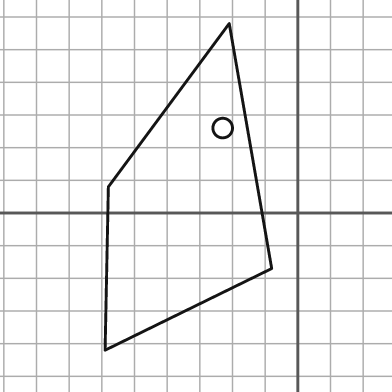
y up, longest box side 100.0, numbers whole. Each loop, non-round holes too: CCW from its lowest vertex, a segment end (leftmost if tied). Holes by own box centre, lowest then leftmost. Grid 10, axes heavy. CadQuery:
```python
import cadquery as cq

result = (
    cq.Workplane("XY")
    .moveTo(-59.0, -42.0)
    .lineTo(-8.0, -17.0)
    .lineTo(-21.0, 58.0)
    .lineTo(-58.0, 8.0)
    .close()
    .moveTo(-23.0, 26.0)
    .circle(3.0)
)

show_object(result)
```